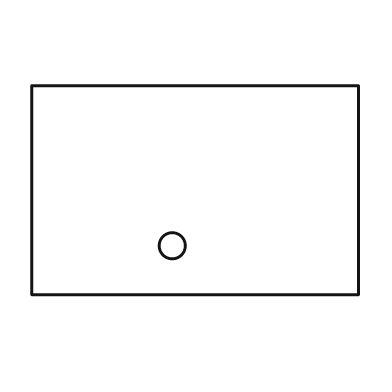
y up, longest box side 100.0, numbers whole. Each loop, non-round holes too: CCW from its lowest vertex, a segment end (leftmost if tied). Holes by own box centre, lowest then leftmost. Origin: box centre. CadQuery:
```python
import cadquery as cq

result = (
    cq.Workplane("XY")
    .moveTo(-50.0, -32.0)
    .lineTo(50.0, -32.0)
    .lineTo(50.0, 32.0)
    .lineTo(-50.0, 32.0)
    .close()
    .moveTo(-7.0, -17.0)
    .circle(4.0)
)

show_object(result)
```